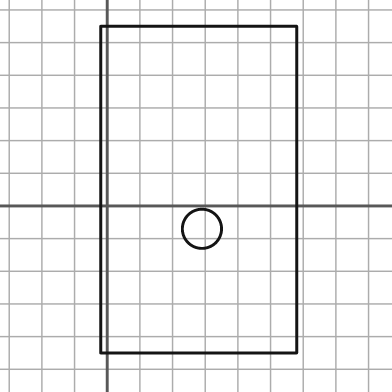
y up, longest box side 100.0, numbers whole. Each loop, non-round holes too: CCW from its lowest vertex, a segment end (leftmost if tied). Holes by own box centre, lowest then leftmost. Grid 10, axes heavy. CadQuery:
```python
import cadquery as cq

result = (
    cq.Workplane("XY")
    .moveTo(-2.0, -45.0)
    .lineTo(58.0, -45.0)
    .lineTo(58.0, 55.0)
    .lineTo(-2.0, 55.0)
    .close()
    .moveTo(29.0, -7.0)
    .circle(6.0)
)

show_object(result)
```